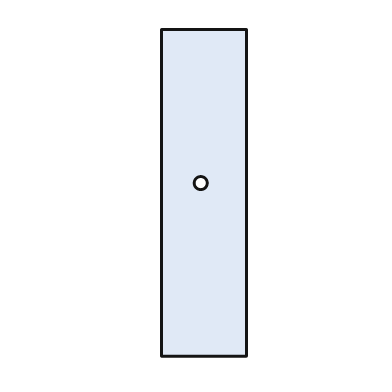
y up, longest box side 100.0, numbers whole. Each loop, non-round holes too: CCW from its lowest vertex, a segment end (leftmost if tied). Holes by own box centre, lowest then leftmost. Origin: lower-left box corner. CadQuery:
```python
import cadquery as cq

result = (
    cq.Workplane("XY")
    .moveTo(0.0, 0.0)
    .lineTo(26.0, 0.0)
    .lineTo(26.0, 100.0)
    .lineTo(0.0, 100.0)
    .close()
    .moveTo(12.0, 53.0)
    .circle(2.0)
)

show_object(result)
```